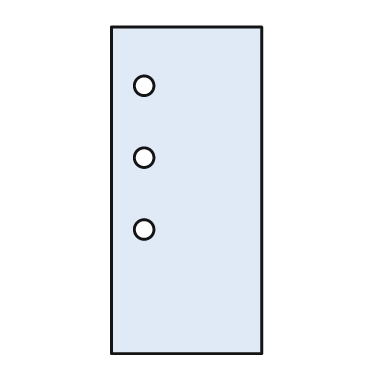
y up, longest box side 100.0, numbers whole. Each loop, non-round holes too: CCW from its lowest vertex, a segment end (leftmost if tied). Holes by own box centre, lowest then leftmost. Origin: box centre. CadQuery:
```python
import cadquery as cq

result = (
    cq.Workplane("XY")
    .moveTo(-23.0, -50.0)
    .lineTo(23.0, -50.0)
    .lineTo(23.0, 50.0)
    .lineTo(-23.0, 50.0)
    .close()
    .moveTo(-13.0, -12.0)
    .circle(3.0)
    .moveTo(-13.0, 10.0)
    .circle(3.0)
    .moveTo(-13.0, 32.0)
    .circle(3.0)
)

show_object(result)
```